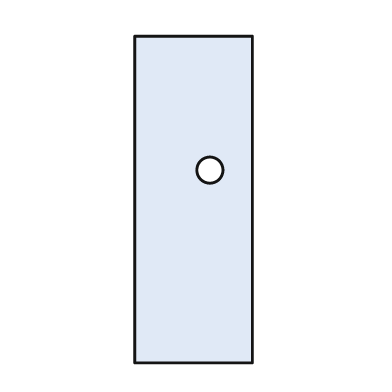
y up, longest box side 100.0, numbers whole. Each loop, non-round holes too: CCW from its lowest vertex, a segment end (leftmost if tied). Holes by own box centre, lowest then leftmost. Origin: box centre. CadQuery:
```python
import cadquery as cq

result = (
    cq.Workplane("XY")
    .moveTo(-18.0, -50.0)
    .lineTo(18.0, -50.0)
    .lineTo(18.0, 50.0)
    .lineTo(-18.0, 50.0)
    .close()
    .moveTo(5.0, 9.0)
    .circle(4.0)
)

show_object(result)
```